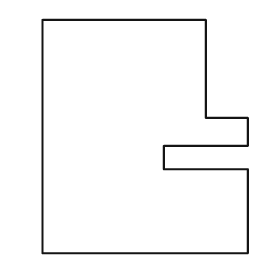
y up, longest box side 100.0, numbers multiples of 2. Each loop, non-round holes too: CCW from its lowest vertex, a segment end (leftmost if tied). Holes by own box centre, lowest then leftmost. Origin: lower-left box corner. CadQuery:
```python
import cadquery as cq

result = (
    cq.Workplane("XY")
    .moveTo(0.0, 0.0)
    .lineTo(88.0, 0.0)
    .lineTo(88.0, 36.0)
    .lineTo(52.0, 36.0)
    .lineTo(52.0, 46.0)
    .lineTo(88.0, 46.0)
    .lineTo(88.0, 58.0)
    .lineTo(70.0, 58.0)
    .lineTo(70.0, 100.0)
    .lineTo(0.0, 100.0)
    .close()
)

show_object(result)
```